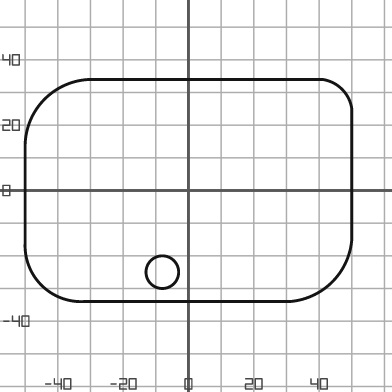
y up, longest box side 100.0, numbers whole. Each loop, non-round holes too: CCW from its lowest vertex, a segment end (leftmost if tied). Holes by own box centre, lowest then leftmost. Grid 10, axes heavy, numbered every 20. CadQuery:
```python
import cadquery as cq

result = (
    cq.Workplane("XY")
    .moveTo(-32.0, -34.0)
    .lineTo(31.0, -34.0)
    .threePointArc((44.0, -28.0), (50.0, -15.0))
    .lineTo(50.0, 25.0)
    .threePointArc((47.0, 31.0), (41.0, 34.0))
    .lineTo(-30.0, 34.0)
    .threePointArc((-44.0, 28.0), (-50.0, 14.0))
    .lineTo(-50.0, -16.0)
    .threePointArc((-45.0, -29.0), (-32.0, -34.0))
    .close()
    .moveTo(-8.0, -25.0)
    .circle(5.0)
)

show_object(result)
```